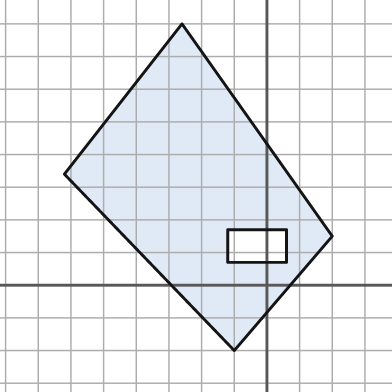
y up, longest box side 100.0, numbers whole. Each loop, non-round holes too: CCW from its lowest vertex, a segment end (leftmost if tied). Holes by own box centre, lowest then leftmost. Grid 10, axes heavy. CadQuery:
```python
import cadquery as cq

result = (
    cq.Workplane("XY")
    .moveTo(-10.0, -20.0)
    .lineTo(20.0, 15.0)
    .lineTo(-26.0, 80.0)
    .lineTo(-62.0, 34.0)
    .close()
    .moveTo(-12.0, 7.0)
    .lineTo(6.0, 7.0)
    .lineTo(6.0, 17.0)
    .lineTo(-12.0, 17.0)
    .close()
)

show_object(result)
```